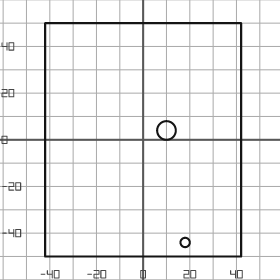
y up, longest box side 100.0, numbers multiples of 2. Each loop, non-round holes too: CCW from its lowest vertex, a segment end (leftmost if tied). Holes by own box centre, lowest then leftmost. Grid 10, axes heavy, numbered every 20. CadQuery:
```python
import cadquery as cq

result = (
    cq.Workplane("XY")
    .moveTo(-42.0, -50.0)
    .lineTo(42.0, -50.0)
    .lineTo(42.0, 50.0)
    .lineTo(-42.0, 50.0)
    .close()
    .moveTo(18.0, -44.0)
    .circle(2.0)
    .moveTo(10.0, 4.0)
    .circle(4.0)
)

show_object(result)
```